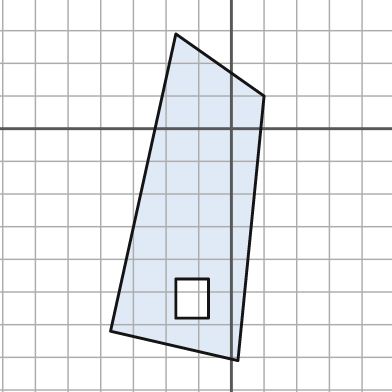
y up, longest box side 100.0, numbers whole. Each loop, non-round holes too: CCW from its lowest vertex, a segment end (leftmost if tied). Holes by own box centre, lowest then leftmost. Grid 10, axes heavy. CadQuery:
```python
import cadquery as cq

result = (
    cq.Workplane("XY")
    .moveTo(2.0, -71.0)
    .lineTo(10.0, 10.0)
    .lineTo(-17.0, 29.0)
    .lineTo(-37.0, -62.0)
    .close()
    .moveTo(-17.0, -58.0)
    .lineTo(-7.0, -58.0)
    .lineTo(-7.0, -46.0)
    .lineTo(-17.0, -46.0)
    .close()
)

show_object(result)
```